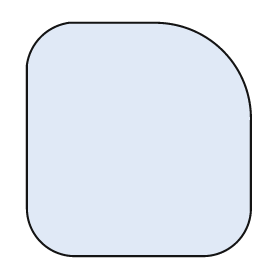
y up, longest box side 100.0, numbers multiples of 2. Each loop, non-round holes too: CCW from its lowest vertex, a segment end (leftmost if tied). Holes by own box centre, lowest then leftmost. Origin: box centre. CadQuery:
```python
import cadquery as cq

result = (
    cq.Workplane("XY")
    .moveTo(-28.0, -50.0)
    .lineTo(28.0, -50.0)
    .threePointArc((42.0, -44.0), (48.0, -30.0))
    .lineTo(48.0, 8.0)
    .threePointArc((36.0, 38.0), (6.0, 50.0))
    .lineTo(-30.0, 50.0)
    .threePointArc((-42.0, 44.0), (-48.0, 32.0))
    .lineTo(-48.0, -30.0)
    .threePointArc((-42.0, -44.0), (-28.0, -50.0))
    .close()
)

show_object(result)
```